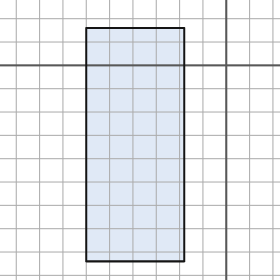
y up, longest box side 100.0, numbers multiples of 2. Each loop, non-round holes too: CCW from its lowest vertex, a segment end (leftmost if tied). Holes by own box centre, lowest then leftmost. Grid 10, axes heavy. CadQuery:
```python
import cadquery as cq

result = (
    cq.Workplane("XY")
    .moveTo(-60.0, -84.0)
    .lineTo(-18.0, -84.0)
    .lineTo(-18.0, 16.0)
    .lineTo(-60.0, 16.0)
    .close()
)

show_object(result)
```